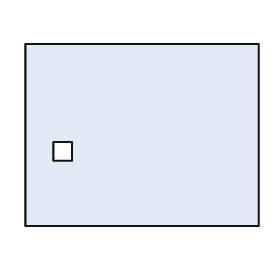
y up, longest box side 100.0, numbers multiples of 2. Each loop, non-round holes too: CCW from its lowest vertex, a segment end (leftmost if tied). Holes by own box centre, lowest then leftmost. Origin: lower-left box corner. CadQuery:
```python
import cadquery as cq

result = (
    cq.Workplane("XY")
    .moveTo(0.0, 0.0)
    .lineTo(100.0, 0.0)
    .lineTo(100.0, 78.0)
    .lineTo(0.0, 78.0)
    .close()
    .moveTo(12.0, 28.0)
    .lineTo(20.0, 28.0)
    .lineTo(20.0, 36.0)
    .lineTo(12.0, 36.0)
    .close()
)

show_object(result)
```